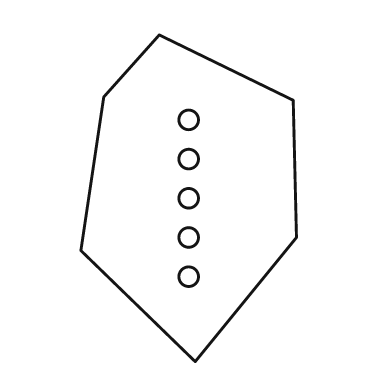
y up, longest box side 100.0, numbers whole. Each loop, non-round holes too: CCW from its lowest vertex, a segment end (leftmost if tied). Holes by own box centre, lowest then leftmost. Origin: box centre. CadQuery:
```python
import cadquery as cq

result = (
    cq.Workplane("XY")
    .moveTo(2.0, -50.0)
    .lineTo(33.0, -12.0)
    .lineTo(32.0, 30.0)
    .lineTo(-9.0, 50.0)
    .lineTo(-26.0, 31.0)
    .lineTo(-33.0, -16.0)
    .close()
    .moveTo(0.0, -24.0)
    .circle(3.0)
    .moveTo(0.0, -12.0)
    .circle(3.0)
    .moveTo(0.0, 0.0)
    .circle(3.0)
    .moveTo(0.0, 12.0)
    .circle(3.0)
    .moveTo(0.0, 24.0)
    .circle(3.0)
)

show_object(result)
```